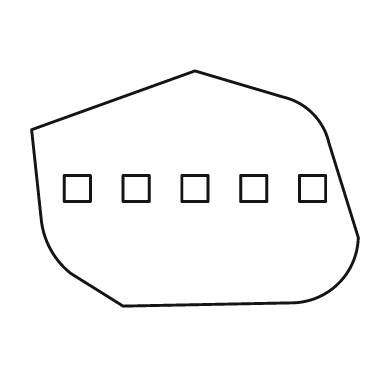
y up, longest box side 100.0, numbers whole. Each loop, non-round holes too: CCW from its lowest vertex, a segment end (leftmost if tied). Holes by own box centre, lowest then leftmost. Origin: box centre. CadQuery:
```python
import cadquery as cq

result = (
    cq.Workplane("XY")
    .moveTo(-22.0, -36.0)
    .lineTo(30.0, -35.0)
    .threePointArc((44.0, -29.0), (50.0, -15.0))
    .lineTo(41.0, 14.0)
    .threePointArc((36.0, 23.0), (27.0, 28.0))
    .lineTo(0.0, 36.0)
    .lineTo(-50.0, 18.0)
    .lineTo(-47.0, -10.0)
    .threePointArc((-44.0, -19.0), (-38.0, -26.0))
    .close()
    .moveTo(-40.0, -4.0)
    .lineTo(-32.0, -4.0)
    .lineTo(-32.0, 4.0)
    .lineTo(-40.0, 4.0)
    .close()
    .moveTo(-22.0, -4.0)
    .lineTo(-14.0, -4.0)
    .lineTo(-14.0, 4.0)
    .lineTo(-22.0, 4.0)
    .close()
    .moveTo(-4.0, -4.0)
    .lineTo(4.0, -4.0)
    .lineTo(4.0, 4.0)
    .lineTo(-4.0, 4.0)
    .close()
    .moveTo(14.0, -4.0)
    .lineTo(22.0, -4.0)
    .lineTo(22.0, 4.0)
    .lineTo(14.0, 4.0)
    .close()
    .moveTo(32.0, -4.0)
    .lineTo(40.0, -4.0)
    .lineTo(40.0, 4.0)
    .lineTo(32.0, 4.0)
    .close()
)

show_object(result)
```